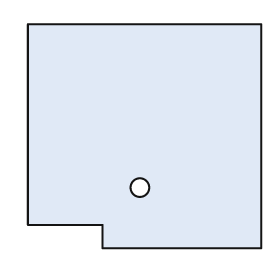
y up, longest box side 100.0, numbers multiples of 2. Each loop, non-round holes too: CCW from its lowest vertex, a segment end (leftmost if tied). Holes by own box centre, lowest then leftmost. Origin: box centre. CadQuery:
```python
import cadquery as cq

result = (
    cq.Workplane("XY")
    .moveTo(-18.0, -48.0)
    .lineTo(50.0, -48.0)
    .lineTo(50.0, 48.0)
    .lineTo(-50.0, 48.0)
    .lineTo(-50.0, -38.0)
    .lineTo(-18.0, -38.0)
    .close()
    .moveTo(-2.0, -22.0)
    .circle(4.0)
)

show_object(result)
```